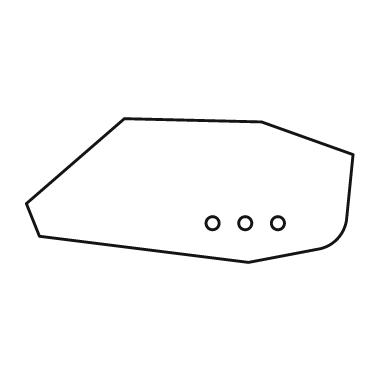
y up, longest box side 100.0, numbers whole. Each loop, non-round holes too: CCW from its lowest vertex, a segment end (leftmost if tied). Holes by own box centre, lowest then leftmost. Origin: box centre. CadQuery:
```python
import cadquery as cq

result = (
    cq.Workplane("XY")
    .moveTo(18.0, -22.0)
    .lineTo(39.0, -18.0)
    .threePointArc((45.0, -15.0), (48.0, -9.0))
    .lineTo(50.0, 11.0)
    .lineTo(22.0, 21.0)
    .lineTo(-20.0, 22.0)
    .lineTo(-50.0, -4.0)
    .lineTo(-46.0, -14.0)
    .close()
    .moveTo(7.0, -10.0)
    .circle(2.0)
    .moveTo(17.0, -10.0)
    .circle(2.0)
    .moveTo(27.0, -10.0)
    .circle(2.0)
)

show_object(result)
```